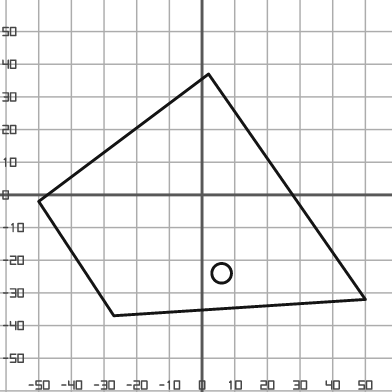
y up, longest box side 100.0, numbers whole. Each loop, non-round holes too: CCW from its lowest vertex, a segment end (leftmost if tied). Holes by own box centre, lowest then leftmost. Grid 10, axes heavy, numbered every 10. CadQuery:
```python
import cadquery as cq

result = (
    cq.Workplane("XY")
    .moveTo(-27.0, -37.0)
    .lineTo(50.0, -32.0)
    .lineTo(2.0, 37.0)
    .lineTo(-50.0, -2.0)
    .close()
    .moveTo(6.0, -24.0)
    .circle(3.0)
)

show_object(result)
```